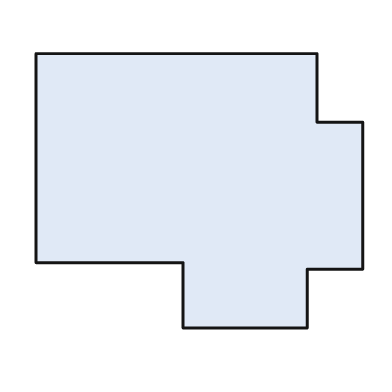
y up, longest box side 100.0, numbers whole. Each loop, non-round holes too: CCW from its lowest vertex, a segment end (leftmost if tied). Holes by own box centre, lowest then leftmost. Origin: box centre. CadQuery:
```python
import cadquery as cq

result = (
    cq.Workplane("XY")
    .moveTo(-5.0, -42.0)
    .lineTo(33.0, -42.0)
    .lineTo(33.0, -24.0)
    .lineTo(50.0, -24.0)
    .lineTo(50.0, 21.0)
    .lineTo(36.0, 21.0)
    .lineTo(36.0, 42.0)
    .lineTo(-50.0, 42.0)
    .lineTo(-50.0, -22.0)
    .lineTo(-5.0, -22.0)
    .close()
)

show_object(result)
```